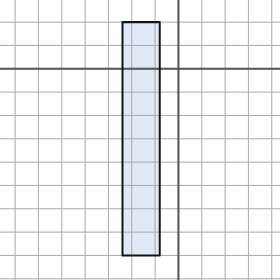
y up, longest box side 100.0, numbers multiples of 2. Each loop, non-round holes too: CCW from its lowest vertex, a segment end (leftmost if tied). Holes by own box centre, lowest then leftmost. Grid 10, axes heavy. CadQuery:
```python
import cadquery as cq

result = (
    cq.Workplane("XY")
    .moveTo(-24.0, -80.0)
    .lineTo(-8.0, -80.0)
    .lineTo(-8.0, 20.0)
    .lineTo(-24.0, 20.0)
    .close()
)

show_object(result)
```